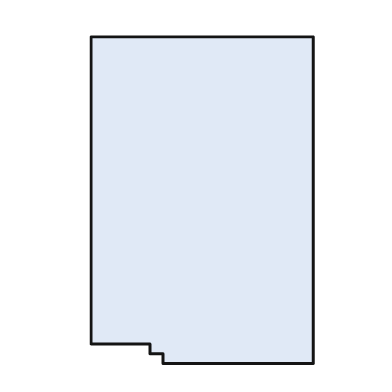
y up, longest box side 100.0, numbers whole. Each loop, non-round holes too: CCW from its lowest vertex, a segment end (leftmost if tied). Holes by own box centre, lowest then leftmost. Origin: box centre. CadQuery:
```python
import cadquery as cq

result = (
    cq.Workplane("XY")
    .moveTo(-12.0, -50.0)
    .lineTo(34.0, -50.0)
    .lineTo(34.0, 50.0)
    .lineTo(-34.0, 50.0)
    .lineTo(-34.0, -44.0)
    .lineTo(-16.0, -44.0)
    .lineTo(-16.0, -47.0)
    .lineTo(-12.0, -47.0)
    .close()
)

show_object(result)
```